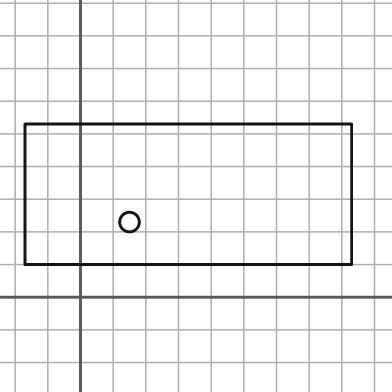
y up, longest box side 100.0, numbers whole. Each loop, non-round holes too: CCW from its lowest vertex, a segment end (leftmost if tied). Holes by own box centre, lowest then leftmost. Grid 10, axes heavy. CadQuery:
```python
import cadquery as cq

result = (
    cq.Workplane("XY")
    .moveTo(-17.0, 10.0)
    .lineTo(83.0, 10.0)
    .lineTo(83.0, 53.0)
    .lineTo(-17.0, 53.0)
    .close()
    .moveTo(15.0, 23.0)
    .circle(3.0)
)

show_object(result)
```